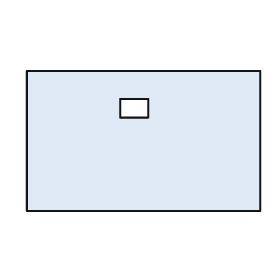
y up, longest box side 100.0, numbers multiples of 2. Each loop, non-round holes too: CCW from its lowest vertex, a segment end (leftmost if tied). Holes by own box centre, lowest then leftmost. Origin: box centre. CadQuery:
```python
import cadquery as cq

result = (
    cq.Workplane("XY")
    .moveTo(-50.0, -30.0)
    .lineTo(50.0, -30.0)
    .lineTo(50.0, 30.0)
    .lineTo(-50.0, 30.0)
    .close()
    .moveTo(-10.0, 10.0)
    .lineTo(2.0, 10.0)
    .lineTo(2.0, 18.0)
    .lineTo(-10.0, 18.0)
    .close()
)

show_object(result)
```